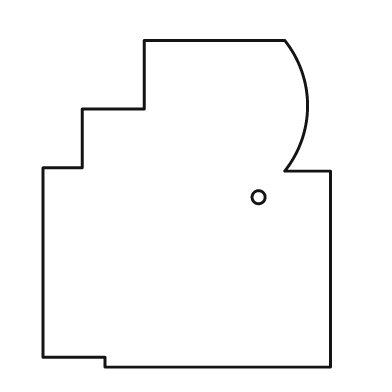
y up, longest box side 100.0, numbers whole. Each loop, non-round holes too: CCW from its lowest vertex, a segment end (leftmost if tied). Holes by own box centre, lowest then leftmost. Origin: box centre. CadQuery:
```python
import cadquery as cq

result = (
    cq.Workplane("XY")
    .moveTo(-25.0, -50.0)
    .lineTo(44.0, -50.0)
    .lineTo(44.0, 10.0)
    .lineTo(30.0, 10.0)
    .threePointArc((37.0, 30.0), (30.0, 50.0))
    .lineTo(-13.0, 50.0)
    .lineTo(-13.0, 29.0)
    .lineTo(-32.0, 29.0)
    .lineTo(-32.0, 11.0)
    .lineTo(-44.0, 11.0)
    .lineTo(-44.0, -47.0)
    .lineTo(-25.0, -47.0)
    .close()
    .moveTo(22.0, 2.0)
    .circle(2.0)
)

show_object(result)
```